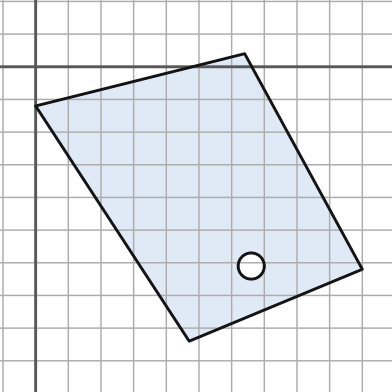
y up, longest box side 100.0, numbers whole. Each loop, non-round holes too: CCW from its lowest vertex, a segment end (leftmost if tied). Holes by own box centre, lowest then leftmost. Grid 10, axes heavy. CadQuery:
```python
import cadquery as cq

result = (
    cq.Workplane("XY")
    .moveTo(47.0, -84.0)
    .lineTo(100.0, -62.0)
    .lineTo(64.0, 4.0)
    .lineTo(0.0, -12.0)
    .close()
    .moveTo(66.0, -61.0)
    .circle(4.0)
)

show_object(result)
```